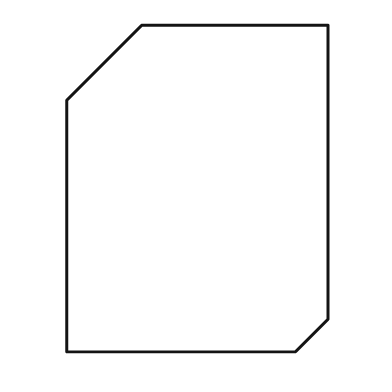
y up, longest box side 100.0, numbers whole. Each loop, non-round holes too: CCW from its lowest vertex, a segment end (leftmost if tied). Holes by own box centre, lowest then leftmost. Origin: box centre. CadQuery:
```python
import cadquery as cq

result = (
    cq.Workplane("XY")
    .moveTo(-40.0, -50.0)
    .lineTo(30.0, -50.0)
    .lineTo(40.0, -40.0)
    .lineTo(40.0, 50.0)
    .lineTo(-17.0, 50.0)
    .lineTo(-40.0, 27.0)
    .close()
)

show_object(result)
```